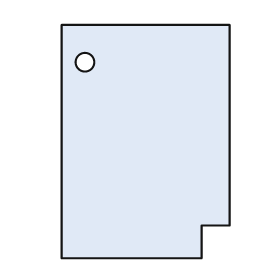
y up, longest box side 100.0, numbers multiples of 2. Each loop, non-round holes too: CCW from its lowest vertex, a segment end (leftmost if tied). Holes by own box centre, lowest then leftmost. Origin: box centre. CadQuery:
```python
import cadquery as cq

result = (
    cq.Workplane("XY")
    .moveTo(-36.0, -50.0)
    .lineTo(24.0, -50.0)
    .lineTo(24.0, -36.0)
    .lineTo(36.0, -36.0)
    .lineTo(36.0, 50.0)
    .lineTo(-36.0, 50.0)
    .close()
    .moveTo(-26.0, 34.0)
    .circle(4.0)
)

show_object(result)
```